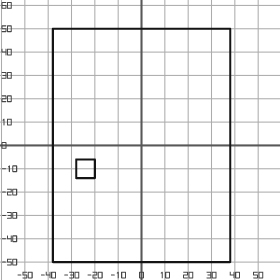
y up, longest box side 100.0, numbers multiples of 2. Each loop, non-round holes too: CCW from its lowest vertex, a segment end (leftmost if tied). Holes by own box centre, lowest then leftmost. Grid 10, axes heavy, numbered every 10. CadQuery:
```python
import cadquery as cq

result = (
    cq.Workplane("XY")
    .moveTo(-38.0, -50.0)
    .lineTo(38.0, -50.0)
    .lineTo(38.0, 50.0)
    .lineTo(-38.0, 50.0)
    .close()
    .moveTo(-28.0, -14.0)
    .lineTo(-20.0, -14.0)
    .lineTo(-20.0, -6.0)
    .lineTo(-28.0, -6.0)
    .close()
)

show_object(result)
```